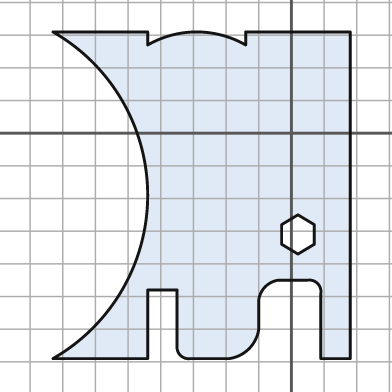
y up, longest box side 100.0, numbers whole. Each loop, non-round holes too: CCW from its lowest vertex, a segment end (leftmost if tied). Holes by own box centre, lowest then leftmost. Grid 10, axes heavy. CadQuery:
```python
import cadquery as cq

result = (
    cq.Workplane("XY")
    .moveTo(-73.0, -69.0)
    .lineTo(-44.0, -69.0)
    .lineTo(-44.0, -48.0)
    .lineTo(-35.0, -48.0)
    .lineTo(-35.0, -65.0)
    .threePointArc((-34.0, -68.0), (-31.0, -69.0))
    .lineTo(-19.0, -69.0)
    .threePointArc((-13.0, -66.0), (-10.0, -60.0))
    .lineTo(-10.0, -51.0)
    .threePointArc((-8.0, -47.0), (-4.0, -45.0))
    .lineTo(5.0, -45.0)
    .threePointArc((8.0, -46.0), (9.0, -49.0))
    .lineTo(9.0, -69.0)
    .lineTo(18.0, -69.0)
    .lineTo(18.0, 31.0)
    .lineTo(-14.0, 31.0)
    .lineTo(-14.0, 27.0)
    .threePointArc((-29.0, 31.0), (-44.0, 27.0))
    .lineTo(-44.0, 31.0)
    .lineTo(-73.0, 31.0)
    .threePointArc((-44.0, -19.0), (-73.0, -69.0))
    .close()
    .moveTo(2.0, -37.0)
    .lineTo(7.0, -34.0)
    .lineTo(7.0, -28.0)
    .lineTo(2.0, -25.0)
    .lineTo(-3.0, -28.0)
    .lineTo(-3.0, -34.0)
    .close()
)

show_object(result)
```